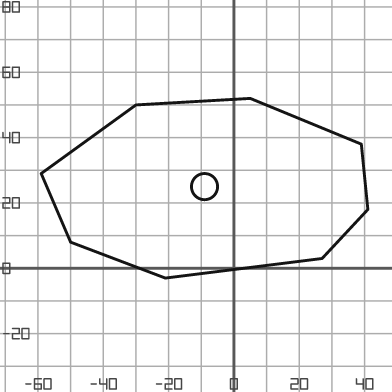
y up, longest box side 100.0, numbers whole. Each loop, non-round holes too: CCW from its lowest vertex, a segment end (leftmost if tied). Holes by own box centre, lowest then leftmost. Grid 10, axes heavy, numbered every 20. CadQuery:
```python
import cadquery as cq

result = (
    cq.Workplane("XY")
    .moveTo(-21.0, -3.0)
    .lineTo(27.0, 3.0)
    .lineTo(41.0, 18.0)
    .lineTo(39.0, 38.0)
    .lineTo(5.0, 52.0)
    .lineTo(-30.0, 50.0)
    .lineTo(-59.0, 29.0)
    .lineTo(-50.0, 8.0)
    .close()
    .moveTo(-9.0, 25.0)
    .circle(4.0)
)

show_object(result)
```